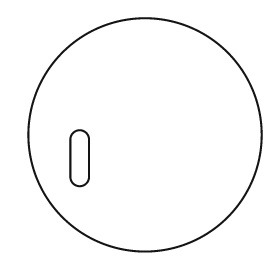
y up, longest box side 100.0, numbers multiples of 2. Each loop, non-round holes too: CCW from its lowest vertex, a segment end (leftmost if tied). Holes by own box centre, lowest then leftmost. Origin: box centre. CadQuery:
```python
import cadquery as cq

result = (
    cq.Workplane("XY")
    .moveTo(0.0, 0.0)
    .circle(50.0)
    .moveTo(-32.0, -18.0)
    .threePointArc((-28.0, -22.0), (-24.0, -18.0))
    .lineTo(-24.0, -2.0)
    .threePointArc((-28.0, 2.0), (-32.0, -2.0))
    .close()
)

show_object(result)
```